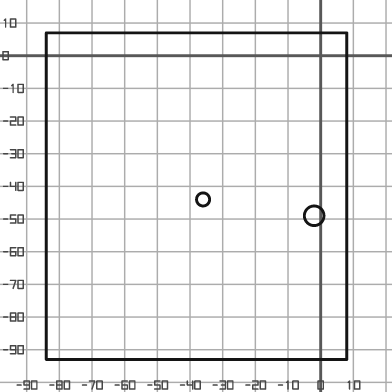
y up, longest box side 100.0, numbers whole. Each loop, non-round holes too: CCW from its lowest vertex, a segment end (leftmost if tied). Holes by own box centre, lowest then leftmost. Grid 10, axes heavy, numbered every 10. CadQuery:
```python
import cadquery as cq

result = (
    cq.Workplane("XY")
    .moveTo(-84.0, -93.0)
    .lineTo(8.0, -93.0)
    .lineTo(8.0, 7.0)
    .lineTo(-84.0, 7.0)
    .close()
    .moveTo(-2.0, -49.0)
    .circle(3.0)
    .moveTo(-36.0, -44.0)
    .circle(2.0)
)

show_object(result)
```